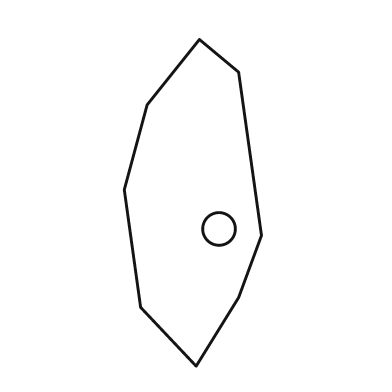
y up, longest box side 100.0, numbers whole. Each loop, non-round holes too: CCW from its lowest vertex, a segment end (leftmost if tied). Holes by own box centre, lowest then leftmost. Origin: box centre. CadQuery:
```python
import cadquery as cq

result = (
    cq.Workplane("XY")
    .moveTo(1.0, -50.0)
    .lineTo(14.0, -29.0)
    .lineTo(21.0, -10.0)
    .lineTo(14.0, 40.0)
    .lineTo(2.0, 50.0)
    .lineTo(-14.0, 30.0)
    .lineTo(-21.0, 4.0)
    .lineTo(-16.0, -32.0)
    .close()
    .moveTo(8.0, -8.0)
    .circle(5.0)
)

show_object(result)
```